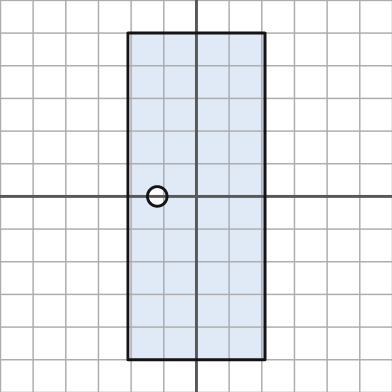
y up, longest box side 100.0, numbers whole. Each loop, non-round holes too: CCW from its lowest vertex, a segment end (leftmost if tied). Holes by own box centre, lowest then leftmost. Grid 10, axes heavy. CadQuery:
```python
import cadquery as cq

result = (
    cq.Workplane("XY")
    .moveTo(-21.0, -50.0)
    .lineTo(21.0, -50.0)
    .lineTo(21.0, 50.0)
    .lineTo(-21.0, 50.0)
    .close()
    .moveTo(-12.0, 0.0)
    .circle(3.0)
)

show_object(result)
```